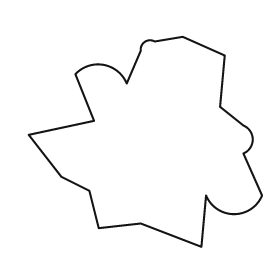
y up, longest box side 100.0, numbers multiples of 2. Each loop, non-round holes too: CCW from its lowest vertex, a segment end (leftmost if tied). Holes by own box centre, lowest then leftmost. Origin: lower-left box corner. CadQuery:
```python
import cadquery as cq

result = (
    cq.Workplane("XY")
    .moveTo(74.0, 0.0)
    .lineTo(76.0, 22.0)
    .threePointArc((88.0, 14.0), (100.0, 22.0))
    .lineTo(92.0, 40.0)
    .threePointArc((96.0, 46.0), (92.0, 52.0))
    .lineTo(82.0, 60.0)
    .lineTo(84.0, 82.0)
    .lineTo(66.0, 90.0)
    .lineTo(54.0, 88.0)
    .threePointArc((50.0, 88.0), (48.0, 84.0))
    .lineTo(42.0, 70.0)
    .threePointArc((32.0, 78.0), (20.0, 74.0))
    .lineTo(28.0, 54.0)
    .lineTo(0.0, 48.0)
    .lineTo(14.0, 30.0)
    .lineTo(26.0, 24.0)
    .lineTo(30.0, 8.0)
    .lineTo(48.0, 10.0)
    .close()
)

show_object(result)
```